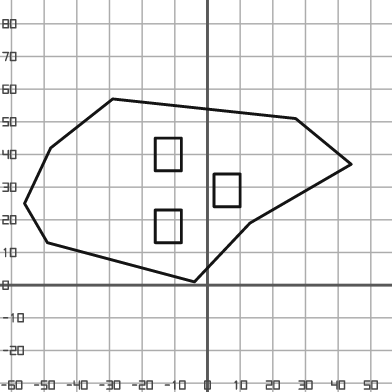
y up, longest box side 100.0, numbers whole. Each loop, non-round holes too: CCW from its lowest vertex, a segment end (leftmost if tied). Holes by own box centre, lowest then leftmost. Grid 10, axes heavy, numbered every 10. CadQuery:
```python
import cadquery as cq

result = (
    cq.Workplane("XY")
    .moveTo(-4.0, 1.0)
    .lineTo(13.0, 19.0)
    .lineTo(44.0, 37.0)
    .lineTo(27.0, 51.0)
    .lineTo(-29.0, 57.0)
    .lineTo(-48.0, 42.0)
    .lineTo(-56.0, 25.0)
    .lineTo(-49.0, 13.0)
    .close()
    .moveTo(-16.0, 13.0)
    .lineTo(-8.0, 13.0)
    .lineTo(-8.0, 23.0)
    .lineTo(-16.0, 23.0)
    .close()
    .moveTo(2.0, 24.0)
    .lineTo(10.0, 24.0)
    .lineTo(10.0, 34.0)
    .lineTo(2.0, 34.0)
    .close()
    .moveTo(-16.0, 35.0)
    .lineTo(-8.0, 35.0)
    .lineTo(-8.0, 45.0)
    .lineTo(-16.0, 45.0)
    .close()
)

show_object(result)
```